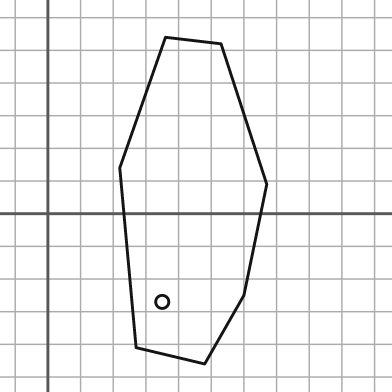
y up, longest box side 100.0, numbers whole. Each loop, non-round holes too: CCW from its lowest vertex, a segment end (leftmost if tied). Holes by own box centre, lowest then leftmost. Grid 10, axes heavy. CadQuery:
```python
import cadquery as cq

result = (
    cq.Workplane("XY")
    .moveTo(48.0, -46.0)
    .lineTo(60.0, -25.0)
    .lineTo(67.0, 9.0)
    .lineTo(53.0, 52.0)
    .lineTo(36.0, 54.0)
    .lineTo(22.0, 14.0)
    .lineTo(27.0, -41.0)
    .close()
    .moveTo(35.0, -27.0)
    .circle(2.0)
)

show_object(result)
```